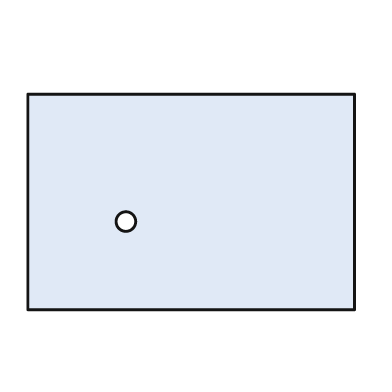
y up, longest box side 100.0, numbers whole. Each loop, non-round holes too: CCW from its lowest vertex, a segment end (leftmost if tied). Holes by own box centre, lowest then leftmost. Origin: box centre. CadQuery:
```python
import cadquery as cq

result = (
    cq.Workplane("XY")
    .moveTo(-50.0, -33.0)
    .lineTo(50.0, -33.0)
    .lineTo(50.0, 33.0)
    .lineTo(-50.0, 33.0)
    .close()
    .moveTo(-20.0, -6.0)
    .circle(3.0)
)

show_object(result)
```